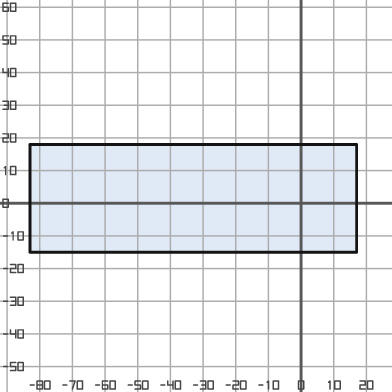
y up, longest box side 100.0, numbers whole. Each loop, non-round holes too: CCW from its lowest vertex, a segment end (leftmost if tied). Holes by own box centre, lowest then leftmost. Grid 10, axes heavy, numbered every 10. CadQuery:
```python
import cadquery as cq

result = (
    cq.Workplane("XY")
    .moveTo(-83.0, -15.0)
    .lineTo(17.0, -15.0)
    .lineTo(17.0, 18.0)
    .lineTo(-83.0, 18.0)
    .close()
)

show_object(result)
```